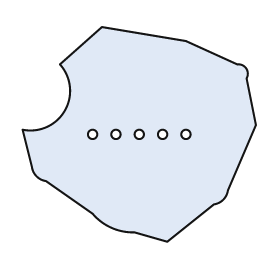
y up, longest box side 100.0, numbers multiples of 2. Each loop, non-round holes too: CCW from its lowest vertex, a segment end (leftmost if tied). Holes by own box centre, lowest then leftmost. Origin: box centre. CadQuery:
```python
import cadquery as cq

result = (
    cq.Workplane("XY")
    .moveTo(12.0, -46.0)
    .lineTo(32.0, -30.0)
    .threePointArc((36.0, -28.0), (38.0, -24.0))
    .lineTo(50.0, 4.0)
    .lineTo(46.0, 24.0)
    .threePointArc((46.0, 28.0), (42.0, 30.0))
    .lineTo(20.0, 40.0)
    .lineTo(-16.0, 46.0)
    .lineTo(-34.0, 30.0)
    .threePointArc((-32.0, 10.0), (-50.0, 2.0))
    .lineTo(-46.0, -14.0)
    .threePointArc((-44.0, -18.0), (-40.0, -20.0))
    .lineTo(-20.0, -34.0)
    .threePointArc((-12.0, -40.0), (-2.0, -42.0))
    .close()
    .moveTo(-20.0, 0.0)
    .circle(2.0)
    .moveTo(-10.0, 0.0)
    .circle(2.0)
    .moveTo(0.0, 0.0)
    .circle(2.0)
    .moveTo(10.0, 0.0)
    .circle(2.0)
    .moveTo(20.0, 0.0)
    .circle(2.0)
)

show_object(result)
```